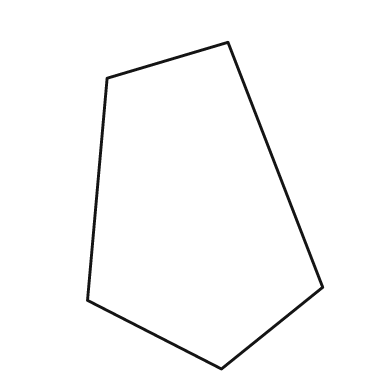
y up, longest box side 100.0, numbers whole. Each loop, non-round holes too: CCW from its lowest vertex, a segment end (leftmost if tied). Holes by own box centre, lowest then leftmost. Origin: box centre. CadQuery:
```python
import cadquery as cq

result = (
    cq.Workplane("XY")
    .moveTo(5.0, -50.0)
    .lineTo(36.0, -25.0)
    .lineTo(7.0, 50.0)
    .lineTo(-30.0, 39.0)
    .lineTo(-36.0, -29.0)
    .close()
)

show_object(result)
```